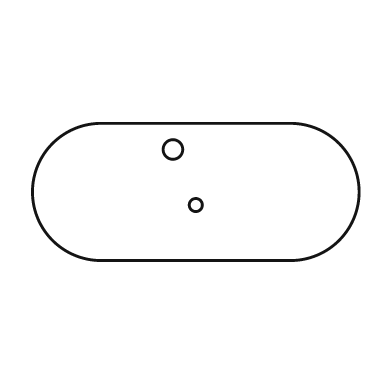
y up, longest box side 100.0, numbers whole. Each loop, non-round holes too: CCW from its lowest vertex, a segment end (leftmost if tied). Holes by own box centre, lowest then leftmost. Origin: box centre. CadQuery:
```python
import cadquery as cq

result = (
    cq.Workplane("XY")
    .moveTo(-29.0, -21.0)
    .lineTo(29.0, -21.0)
    .threePointArc((50.0, 0.0), (29.0, 21.0))
    .lineTo(-29.0, 21.0)
    .threePointArc((-50.0, 0.0), (-29.0, -21.0))
    .close()
    .moveTo(0.0, -4.0)
    .circle(2.0)
    .moveTo(-7.0, 13.0)
    .circle(3.0)
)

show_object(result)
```